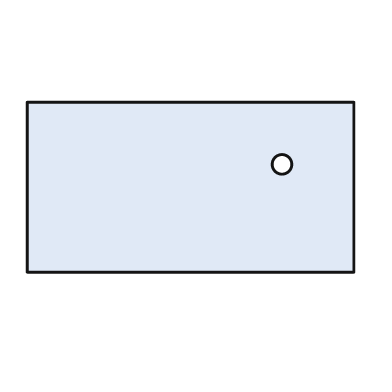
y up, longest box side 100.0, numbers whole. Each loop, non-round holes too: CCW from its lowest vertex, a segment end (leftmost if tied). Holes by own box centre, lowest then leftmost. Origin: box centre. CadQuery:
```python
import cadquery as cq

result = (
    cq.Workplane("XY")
    .moveTo(-50.0, -26.0)
    .lineTo(50.0, -26.0)
    .lineTo(50.0, 26.0)
    .lineTo(-50.0, 26.0)
    .close()
    .moveTo(28.0, 7.0)
    .circle(3.0)
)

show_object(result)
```